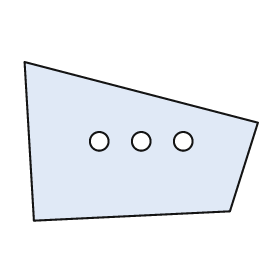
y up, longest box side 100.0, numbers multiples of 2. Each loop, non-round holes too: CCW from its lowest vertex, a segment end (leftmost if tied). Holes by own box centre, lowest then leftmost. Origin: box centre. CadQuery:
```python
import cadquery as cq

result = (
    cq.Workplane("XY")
    .moveTo(-46.0, -34.0)
    .lineTo(38.0, -30.0)
    .lineTo(50.0, 8.0)
    .lineTo(-50.0, 34.0)
    .close()
    .moveTo(-18.0, 0.0)
    .circle(4.0)
    .moveTo(0.0, 0.0)
    .circle(4.0)
    .moveTo(18.0, 0.0)
    .circle(4.0)
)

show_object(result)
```